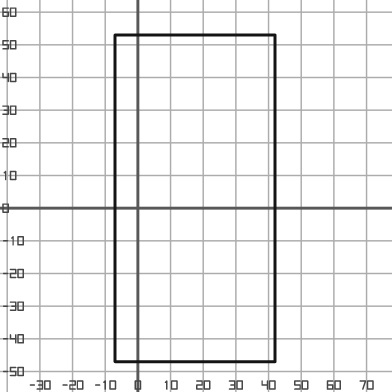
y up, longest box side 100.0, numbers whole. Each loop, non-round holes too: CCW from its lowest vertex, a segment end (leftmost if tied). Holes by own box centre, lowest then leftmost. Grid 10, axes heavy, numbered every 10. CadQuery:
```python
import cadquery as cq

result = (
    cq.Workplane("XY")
    .moveTo(-7.0, -47.0)
    .lineTo(42.0, -47.0)
    .lineTo(42.0, 53.0)
    .lineTo(-7.0, 53.0)
    .close()
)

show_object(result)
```